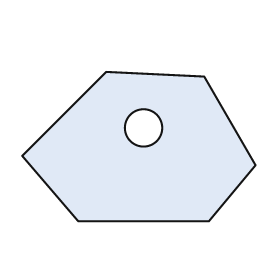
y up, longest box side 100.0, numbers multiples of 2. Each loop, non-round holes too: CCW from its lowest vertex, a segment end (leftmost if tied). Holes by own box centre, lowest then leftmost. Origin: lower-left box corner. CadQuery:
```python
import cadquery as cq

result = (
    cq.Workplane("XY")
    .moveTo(24.0, 0.0)
    .lineTo(80.0, 0.0)
    .lineTo(100.0, 24.0)
    .lineTo(78.0, 62.0)
    .lineTo(36.0, 64.0)
    .lineTo(0.0, 28.0)
    .close()
    .moveTo(52.0, 40.0)
    .circle(8.0)
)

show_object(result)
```